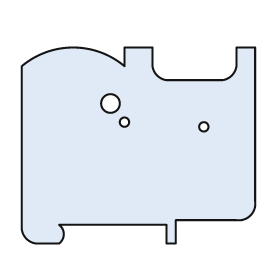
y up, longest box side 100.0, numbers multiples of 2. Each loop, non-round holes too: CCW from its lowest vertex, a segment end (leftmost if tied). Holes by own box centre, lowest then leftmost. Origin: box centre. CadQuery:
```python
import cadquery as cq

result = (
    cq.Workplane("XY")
    .moveTo(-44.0, -42.0)
    .lineTo(-34.0, -42.0)
    .threePointArc((-32.0, -38.0), (-34.0, -34.0))
    .lineTo(12.0, -34.0)
    .lineTo(12.0, -42.0)
    .lineTo(16.0, -42.0)
    .lineTo(16.0, -32.0)
    .lineTo(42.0, -32.0)
    .threePointArc((48.0, -30.0), (50.0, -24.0))
    .lineTo(50.0, 42.0)
    .lineTo(42.0, 42.0)
    .lineTo(42.0, 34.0)
    .threePointArc((40.0, 30.0), (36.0, 28.0))
    .lineTo(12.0, 28.0)
    .threePointArc((8.0, 30.0), (6.0, 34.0))
    .lineTo(6.0, 42.0)
    .lineTo(-6.0, 42.0)
    .lineTo(-6.0, 34.0)
    .threePointArc((-28.0, 42.0), (-50.0, 34.0))
    .lineTo(-50.0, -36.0)
    .threePointArc((-48.0, -40.0), (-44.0, -42.0))
    .close()
    .moveTo(28.0, 8.0)
    .circle(2.0)
    .moveTo(-6.0, 10.0)
    .circle(2.0)
    .moveTo(-12.0, 18.0)
    .circle(4.0)
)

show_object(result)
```